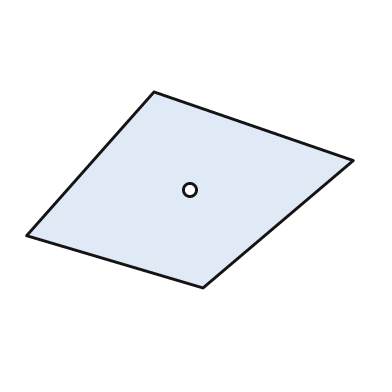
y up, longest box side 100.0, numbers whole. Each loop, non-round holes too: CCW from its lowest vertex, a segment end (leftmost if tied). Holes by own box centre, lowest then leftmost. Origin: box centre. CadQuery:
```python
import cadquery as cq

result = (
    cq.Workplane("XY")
    .moveTo(4.0, -30.0)
    .lineTo(50.0, 9.0)
    .lineTo(-11.0, 30.0)
    .lineTo(-50.0, -14.0)
    .close()
    .moveTo(0.0, 0.0)
    .circle(2.0)
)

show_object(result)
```